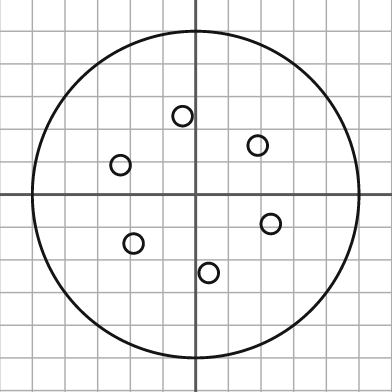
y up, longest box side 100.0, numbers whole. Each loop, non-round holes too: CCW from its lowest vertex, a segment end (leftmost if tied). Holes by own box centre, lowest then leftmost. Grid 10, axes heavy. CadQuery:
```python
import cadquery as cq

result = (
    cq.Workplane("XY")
    .moveTo(0.0, 0.0)
    .circle(50.0)
    .moveTo(4.0, -24.0)
    .circle(3.0)
    .moveTo(-19.0, -15.0)
    .circle(3.0)
    .moveTo(23.0, -9.0)
    .circle(3.0)
    .moveTo(-23.0, 9.0)
    .circle(3.0)
    .moveTo(19.0, 15.0)
    .circle(3.0)
    .moveTo(-4.0, 24.0)
    .circle(3.0)
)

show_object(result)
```